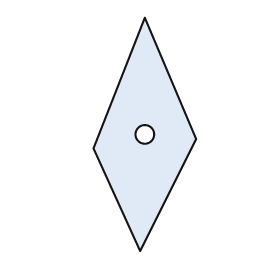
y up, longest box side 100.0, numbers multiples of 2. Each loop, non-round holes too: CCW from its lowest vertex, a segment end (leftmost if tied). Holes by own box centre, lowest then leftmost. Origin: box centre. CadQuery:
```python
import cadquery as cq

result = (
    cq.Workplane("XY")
    .moveTo(-2.0, -50.0)
    .lineTo(22.0, -2.0)
    .lineTo(0.0, 50.0)
    .lineTo(-22.0, -6.0)
    .close()
    .moveTo(0.0, 0.0)
    .circle(4.0)
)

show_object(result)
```